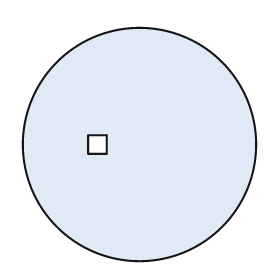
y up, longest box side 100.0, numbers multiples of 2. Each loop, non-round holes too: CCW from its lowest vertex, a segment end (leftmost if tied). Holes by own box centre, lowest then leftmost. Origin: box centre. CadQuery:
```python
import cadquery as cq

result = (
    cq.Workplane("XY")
    .moveTo(0.0, 0.0)
    .circle(50.0)
    .moveTo(-22.0, -4.0)
    .lineTo(-14.0, -4.0)
    .lineTo(-14.0, 4.0)
    .lineTo(-22.0, 4.0)
    .close()
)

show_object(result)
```